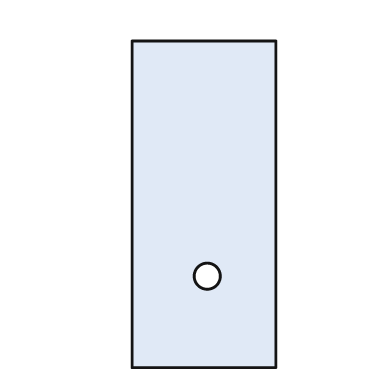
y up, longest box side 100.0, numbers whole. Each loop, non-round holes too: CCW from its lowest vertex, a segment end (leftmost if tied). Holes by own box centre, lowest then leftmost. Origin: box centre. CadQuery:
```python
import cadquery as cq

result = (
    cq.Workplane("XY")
    .moveTo(-22.0, -50.0)
    .lineTo(22.0, -50.0)
    .lineTo(22.0, 50.0)
    .lineTo(-22.0, 50.0)
    .close()
    .moveTo(1.0, -22.0)
    .circle(4.0)
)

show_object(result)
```